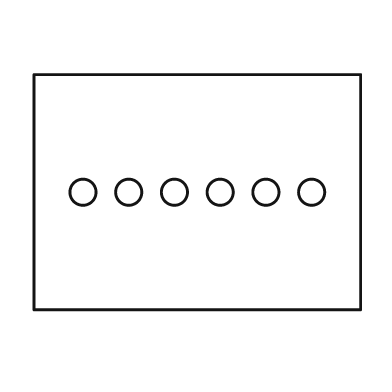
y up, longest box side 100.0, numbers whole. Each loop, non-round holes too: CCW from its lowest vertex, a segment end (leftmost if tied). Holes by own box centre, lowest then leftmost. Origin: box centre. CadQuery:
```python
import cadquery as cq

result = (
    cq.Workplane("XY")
    .moveTo(-50.0, -36.0)
    .lineTo(50.0, -36.0)
    .lineTo(50.0, 36.0)
    .lineTo(-50.0, 36.0)
    .close()
    .moveTo(-35.0, 0.0)
    .circle(4.0)
    .moveTo(-21.0, 0.0)
    .circle(4.0)
    .moveTo(-7.0, 0.0)
    .circle(4.0)
    .moveTo(7.0, 0.0)
    .circle(4.0)
    .moveTo(21.0, 0.0)
    .circle(4.0)
    .moveTo(35.0, 0.0)
    .circle(4.0)
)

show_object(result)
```